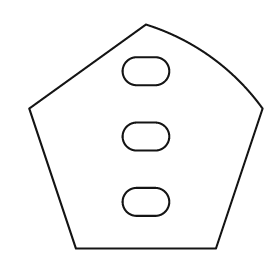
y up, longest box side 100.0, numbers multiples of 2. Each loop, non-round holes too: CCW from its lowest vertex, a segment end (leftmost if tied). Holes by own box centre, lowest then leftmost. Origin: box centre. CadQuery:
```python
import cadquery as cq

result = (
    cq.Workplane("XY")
    .moveTo(-30.0, -48.0)
    .lineTo(30.0, -48.0)
    .lineTo(50.0, 12.0)
    .threePointArc((28.0, 34.0), (0.0, 48.0))
    .lineTo(-50.0, 12.0)
    .close()
    .moveTo(-4.0, -34.0)
    .lineTo(4.0, -34.0)
    .threePointArc((10.0, -28.0), (4.0, -22.0))
    .lineTo(-4.0, -22.0)
    .threePointArc((-10.0, -28.0), (-4.0, -34.0))
    .close()
    .moveTo(-4.0, -6.0)
    .lineTo(4.0, -6.0)
    .threePointArc((10.0, 0.0), (4.0, 6.0))
    .lineTo(-4.0, 6.0)
    .threePointArc((-10.0, 0.0), (-4.0, -6.0))
    .close()
    .moveTo(-4.0, 22.0)
    .lineTo(4.0, 22.0)
    .threePointArc((10.0, 28.0), (4.0, 34.0))
    .lineTo(-4.0, 34.0)
    .threePointArc((-10.0, 28.0), (-4.0, 22.0))
    .close()
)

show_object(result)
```